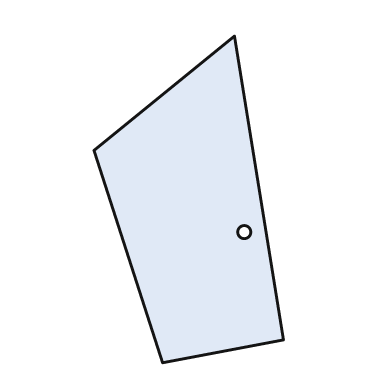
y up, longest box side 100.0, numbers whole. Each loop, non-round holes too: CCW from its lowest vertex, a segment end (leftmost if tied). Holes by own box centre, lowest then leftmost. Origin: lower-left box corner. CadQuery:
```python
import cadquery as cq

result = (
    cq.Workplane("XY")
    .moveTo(21.0, 0.0)
    .lineTo(58.0, 7.0)
    .lineTo(43.0, 100.0)
    .lineTo(0.0, 65.0)
    .close()
    .moveTo(46.0, 40.0)
    .circle(2.0)
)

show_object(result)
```